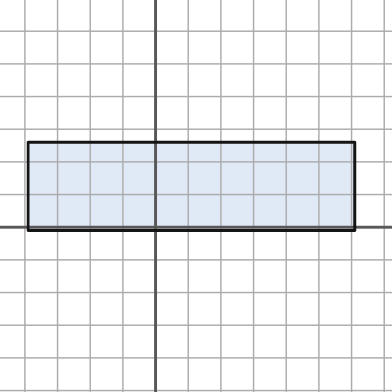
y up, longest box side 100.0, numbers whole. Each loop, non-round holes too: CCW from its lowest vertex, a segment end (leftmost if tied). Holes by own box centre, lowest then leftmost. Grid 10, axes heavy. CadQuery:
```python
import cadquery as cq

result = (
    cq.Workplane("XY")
    .moveTo(-39.0, -1.0)
    .lineTo(61.0, -1.0)
    .lineTo(61.0, 26.0)
    .lineTo(-39.0, 26.0)
    .close()
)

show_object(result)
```